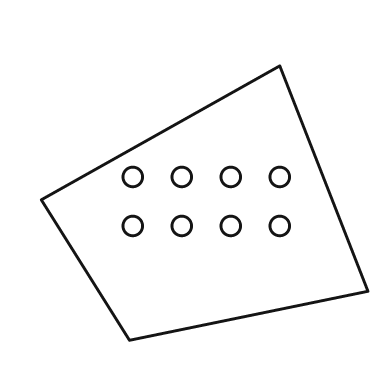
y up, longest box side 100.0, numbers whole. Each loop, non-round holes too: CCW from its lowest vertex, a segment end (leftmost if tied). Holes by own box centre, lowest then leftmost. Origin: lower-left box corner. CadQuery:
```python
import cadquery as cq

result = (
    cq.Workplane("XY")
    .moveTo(27.0, 0.0)
    .lineTo(100.0, 15.0)
    .lineTo(73.0, 84.0)
    .lineTo(0.0, 43.0)
    .close()
    .moveTo(28.0, 35.0)
    .circle(3.0)
    .moveTo(43.0, 35.0)
    .circle(3.0)
    .moveTo(58.0, 35.0)
    .circle(3.0)
    .moveTo(73.0, 35.0)
    .circle(3.0)
    .moveTo(28.0, 50.0)
    .circle(3.0)
    .moveTo(43.0, 50.0)
    .circle(3.0)
    .moveTo(58.0, 50.0)
    .circle(3.0)
    .moveTo(73.0, 50.0)
    .circle(3.0)
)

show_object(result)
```